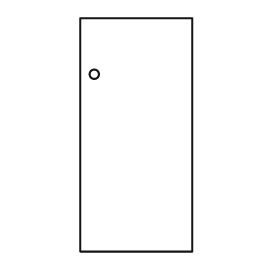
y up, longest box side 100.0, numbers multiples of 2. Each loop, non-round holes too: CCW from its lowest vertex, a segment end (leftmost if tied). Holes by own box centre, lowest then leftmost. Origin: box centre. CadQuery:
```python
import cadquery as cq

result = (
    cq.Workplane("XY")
    .moveTo(-24.0, -50.0)
    .lineTo(24.0, -50.0)
    .lineTo(24.0, 50.0)
    .lineTo(-24.0, 50.0)
    .close()
    .moveTo(-18.0, 26.0)
    .circle(2.0)
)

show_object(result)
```